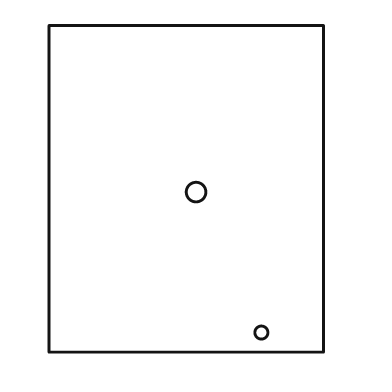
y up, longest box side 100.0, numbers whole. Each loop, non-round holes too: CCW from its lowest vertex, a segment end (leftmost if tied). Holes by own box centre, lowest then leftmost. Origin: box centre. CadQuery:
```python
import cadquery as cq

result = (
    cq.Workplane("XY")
    .moveTo(-42.0, -50.0)
    .lineTo(42.0, -50.0)
    .lineTo(42.0, 50.0)
    .lineTo(-42.0, 50.0)
    .close()
    .moveTo(23.0, -44.0)
    .circle(2.0)
    .moveTo(3.0, -1.0)
    .circle(3.0)
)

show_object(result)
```